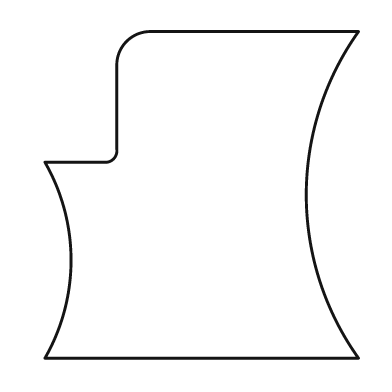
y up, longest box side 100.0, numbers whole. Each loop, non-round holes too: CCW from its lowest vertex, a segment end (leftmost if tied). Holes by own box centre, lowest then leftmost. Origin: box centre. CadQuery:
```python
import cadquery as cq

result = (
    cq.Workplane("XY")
    .moveTo(-48.0, -50.0)
    .lineTo(48.0, -50.0)
    .threePointArc((32.0, 0.0), (48.0, 50.0))
    .lineTo(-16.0, 50.0)
    .threePointArc((-23.0, 47.0), (-26.0, 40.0))
    .lineTo(-26.0, 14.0)
    .threePointArc((-27.0, 11.0), (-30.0, 10.0))
    .lineTo(-48.0, 10.0)
    .threePointArc((-40.0, -20.0), (-48.0, -50.0))
    .close()
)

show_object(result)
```